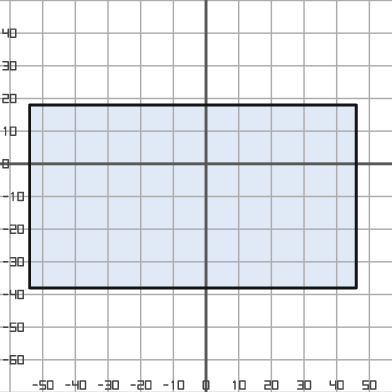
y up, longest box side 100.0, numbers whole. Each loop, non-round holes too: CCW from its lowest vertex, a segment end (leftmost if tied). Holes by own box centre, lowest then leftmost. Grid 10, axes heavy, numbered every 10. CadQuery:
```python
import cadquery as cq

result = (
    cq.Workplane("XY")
    .moveTo(-54.0, -38.0)
    .lineTo(46.0, -38.0)
    .lineTo(46.0, 18.0)
    .lineTo(-54.0, 18.0)
    .close()
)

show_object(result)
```